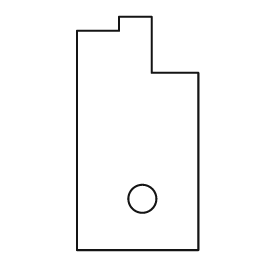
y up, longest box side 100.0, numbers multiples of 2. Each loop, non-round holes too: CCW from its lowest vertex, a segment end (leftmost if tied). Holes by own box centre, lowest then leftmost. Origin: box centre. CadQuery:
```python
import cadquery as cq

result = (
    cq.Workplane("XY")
    .moveTo(-26.0, -50.0)
    .lineTo(26.0, -50.0)
    .lineTo(26.0, 26.0)
    .lineTo(6.0, 26.0)
    .lineTo(6.0, 50.0)
    .lineTo(-8.0, 50.0)
    .lineTo(-8.0, 44.0)
    .lineTo(-26.0, 44.0)
    .close()
    .moveTo(2.0, -28.0)
    .circle(6.0)
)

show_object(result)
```